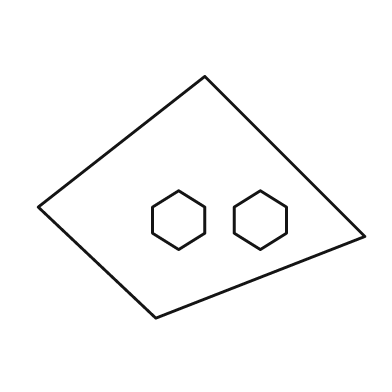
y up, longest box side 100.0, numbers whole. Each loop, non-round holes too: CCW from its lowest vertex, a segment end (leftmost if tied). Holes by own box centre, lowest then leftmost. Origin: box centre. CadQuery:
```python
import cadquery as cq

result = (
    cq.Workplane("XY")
    .moveTo(-14.0, -37.0)
    .lineTo(50.0, -12.0)
    .lineTo(1.0, 37.0)
    .lineTo(-50.0, -3.0)
    .close()
    .moveTo(-7.0, -16.0)
    .lineTo(1.0, -11.0)
    .lineTo(1.0, -3.0)
    .lineTo(-7.0, 2.0)
    .lineTo(-15.0, -3.0)
    .lineTo(-15.0, -11.0)
    .close()
    .moveTo(18.0, -16.0)
    .lineTo(26.0, -11.0)
    .lineTo(26.0, -3.0)
    .lineTo(18.0, 2.0)
    .lineTo(10.0, -3.0)
    .lineTo(10.0, -11.0)
    .close()
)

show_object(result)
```